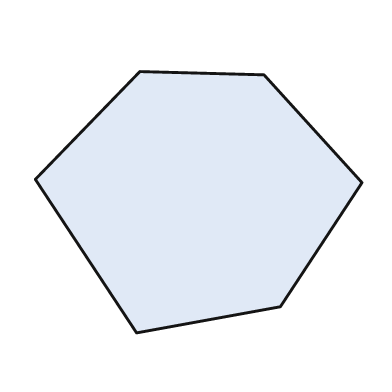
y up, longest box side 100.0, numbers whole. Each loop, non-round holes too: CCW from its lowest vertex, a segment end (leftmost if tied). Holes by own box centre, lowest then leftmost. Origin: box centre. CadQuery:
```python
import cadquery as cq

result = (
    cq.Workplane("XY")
    .moveTo(-19.0, -40.0)
    .lineTo(25.0, -32.0)
    .lineTo(50.0, 6.0)
    .lineTo(20.0, 39.0)
    .lineTo(-18.0, 40.0)
    .lineTo(-50.0, 7.0)
    .close()
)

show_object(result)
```